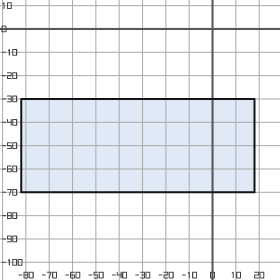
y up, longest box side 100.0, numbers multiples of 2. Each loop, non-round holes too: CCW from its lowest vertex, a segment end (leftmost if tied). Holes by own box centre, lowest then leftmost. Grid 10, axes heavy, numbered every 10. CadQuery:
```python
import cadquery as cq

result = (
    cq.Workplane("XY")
    .moveTo(-82.0, -70.0)
    .lineTo(18.0, -70.0)
    .lineTo(18.0, -30.0)
    .lineTo(-82.0, -30.0)
    .close()
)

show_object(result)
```